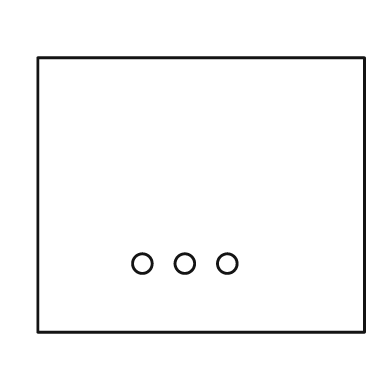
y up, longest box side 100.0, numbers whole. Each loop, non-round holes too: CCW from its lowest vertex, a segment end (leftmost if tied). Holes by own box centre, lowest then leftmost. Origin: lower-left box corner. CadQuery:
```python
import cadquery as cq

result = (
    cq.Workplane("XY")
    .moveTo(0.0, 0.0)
    .lineTo(100.0, 0.0)
    .lineTo(100.0, 84.0)
    .lineTo(0.0, 84.0)
    .close()
    .moveTo(32.0, 21.0)
    .circle(3.0)
    .moveTo(45.0, 21.0)
    .circle(3.0)
    .moveTo(58.0, 21.0)
    .circle(3.0)
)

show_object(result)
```